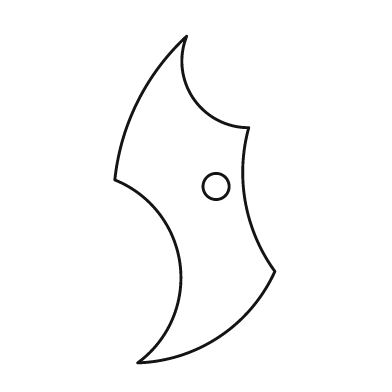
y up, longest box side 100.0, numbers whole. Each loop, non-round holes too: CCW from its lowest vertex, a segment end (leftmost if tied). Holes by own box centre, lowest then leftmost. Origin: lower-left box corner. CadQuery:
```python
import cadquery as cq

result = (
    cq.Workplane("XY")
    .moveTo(7.0, 0.0)
    .threePointArc((32.0, 8.0), (49.0, 28.0))
    .threePointArc((40.0, 49.0), (41.0, 72.0))
    .threePointArc((24.0, 81.0), (22.0, 100.0))
    .threePointArc((7.0, 80.0), (0.0, 56.0))
    .threePointArc((20.0, 30.0), (7.0, 0.0))
    .close()
    .moveTo(31.0, 54.0)
    .circle(4.0)
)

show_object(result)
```